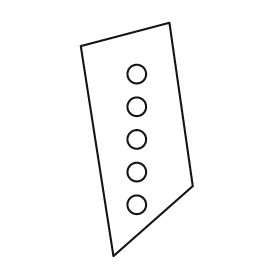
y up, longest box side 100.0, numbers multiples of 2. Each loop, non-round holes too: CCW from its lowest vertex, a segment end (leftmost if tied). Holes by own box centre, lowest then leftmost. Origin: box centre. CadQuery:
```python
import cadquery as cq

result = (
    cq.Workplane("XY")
    .moveTo(-10.0, -50.0)
    .lineTo(24.0, -20.0)
    .lineTo(14.0, 50.0)
    .lineTo(-24.0, 40.0)
    .close()
    .moveTo(0.0, -28.0)
    .circle(4.0)
    .moveTo(0.0, -14.0)
    .circle(4.0)
    .moveTo(0.0, 0.0)
    .circle(4.0)
    .moveTo(0.0, 14.0)
    .circle(4.0)
    .moveTo(0.0, 28.0)
    .circle(4.0)
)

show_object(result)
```